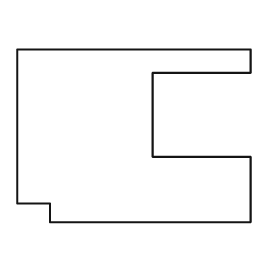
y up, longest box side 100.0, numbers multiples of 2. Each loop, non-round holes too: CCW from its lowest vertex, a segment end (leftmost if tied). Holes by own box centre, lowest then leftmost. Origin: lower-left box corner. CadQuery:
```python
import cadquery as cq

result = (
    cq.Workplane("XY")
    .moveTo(14.0, 0.0)
    .lineTo(100.0, 0.0)
    .lineTo(100.0, 28.0)
    .lineTo(58.0, 28.0)
    .lineTo(58.0, 64.0)
    .lineTo(100.0, 64.0)
    .lineTo(100.0, 74.0)
    .lineTo(0.0, 74.0)
    .lineTo(0.0, 8.0)
    .lineTo(14.0, 8.0)
    .close()
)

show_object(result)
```